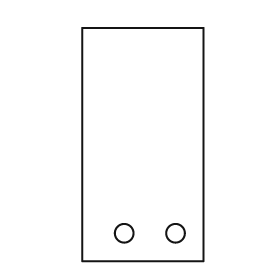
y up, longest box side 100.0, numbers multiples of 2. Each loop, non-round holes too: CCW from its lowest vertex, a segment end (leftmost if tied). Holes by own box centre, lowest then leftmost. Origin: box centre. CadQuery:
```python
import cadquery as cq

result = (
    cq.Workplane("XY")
    .moveTo(-26.0, -50.0)
    .lineTo(26.0, -50.0)
    .lineTo(26.0, 50.0)
    .lineTo(-26.0, 50.0)
    .close()
    .moveTo(-8.0, -38.0)
    .circle(4.0)
    .moveTo(14.0, -38.0)
    .circle(4.0)
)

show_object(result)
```